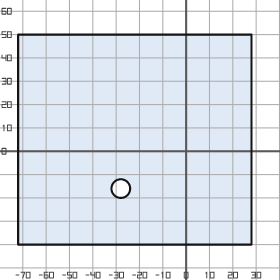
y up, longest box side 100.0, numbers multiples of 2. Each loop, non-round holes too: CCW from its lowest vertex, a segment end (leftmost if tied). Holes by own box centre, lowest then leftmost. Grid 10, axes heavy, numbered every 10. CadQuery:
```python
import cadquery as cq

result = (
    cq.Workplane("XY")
    .moveTo(-72.0, -40.0)
    .lineTo(28.0, -40.0)
    .lineTo(28.0, 50.0)
    .lineTo(-72.0, 50.0)
    .close()
    .moveTo(-28.0, -16.0)
    .circle(4.0)
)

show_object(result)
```